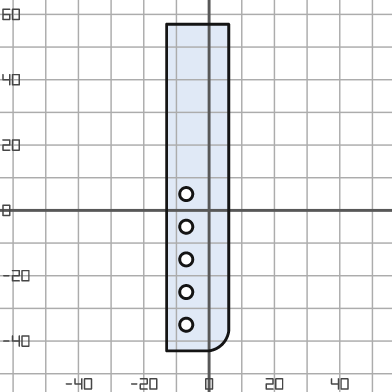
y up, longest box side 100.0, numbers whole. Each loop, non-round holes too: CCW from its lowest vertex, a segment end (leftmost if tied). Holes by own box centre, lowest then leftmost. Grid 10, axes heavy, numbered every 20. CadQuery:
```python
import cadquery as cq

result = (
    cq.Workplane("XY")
    .moveTo(-13.0, -43.0)
    .lineTo(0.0, -43.0)
    .threePointArc((4.0, -41.0), (6.0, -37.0))
    .lineTo(6.0, 57.0)
    .lineTo(-13.0, 57.0)
    .close()
    .moveTo(-7.0, -35.0)
    .circle(2.0)
    .moveTo(-7.0, -25.0)
    .circle(2.0)
    .moveTo(-7.0, -15.0)
    .circle(2.0)
    .moveTo(-7.0, -5.0)
    .circle(2.0)
    .moveTo(-7.0, 5.0)
    .circle(2.0)
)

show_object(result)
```